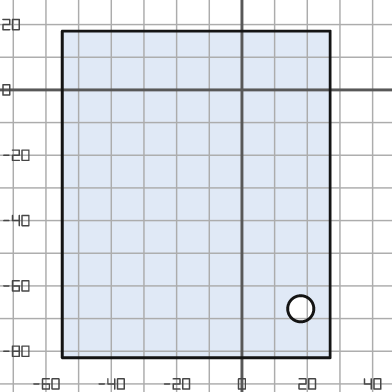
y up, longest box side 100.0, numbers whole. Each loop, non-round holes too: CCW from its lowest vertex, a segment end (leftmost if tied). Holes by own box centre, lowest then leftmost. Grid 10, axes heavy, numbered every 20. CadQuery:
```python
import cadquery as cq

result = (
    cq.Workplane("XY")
    .moveTo(-55.0, -82.0)
    .lineTo(27.0, -82.0)
    .lineTo(27.0, 18.0)
    .lineTo(-55.0, 18.0)
    .close()
    .moveTo(18.0, -67.0)
    .circle(4.0)
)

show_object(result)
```